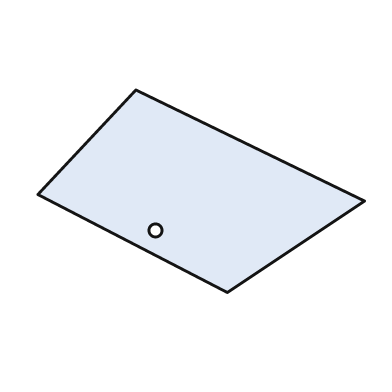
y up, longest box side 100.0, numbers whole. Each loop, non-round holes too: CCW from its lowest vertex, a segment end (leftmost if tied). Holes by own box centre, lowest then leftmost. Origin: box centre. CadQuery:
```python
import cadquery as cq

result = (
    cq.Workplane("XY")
    .moveTo(8.0, -31.0)
    .lineTo(50.0, -3.0)
    .lineTo(-20.0, 31.0)
    .lineTo(-50.0, -1.0)
    .close()
    .moveTo(-14.0, -12.0)
    .circle(2.0)
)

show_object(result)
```